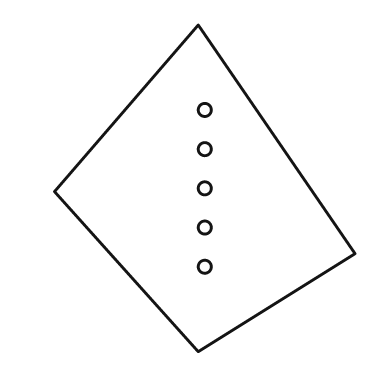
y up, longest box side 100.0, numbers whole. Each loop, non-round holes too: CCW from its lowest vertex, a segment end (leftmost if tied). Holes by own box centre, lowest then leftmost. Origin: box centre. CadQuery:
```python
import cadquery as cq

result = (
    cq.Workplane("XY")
    .moveTo(-2.0, -50.0)
    .lineTo(46.0, -20.0)
    .lineTo(-2.0, 50.0)
    .lineTo(-46.0, -1.0)
    .close()
    .moveTo(0.0, -24.0)
    .circle(2.0)
    .moveTo(0.0, -12.0)
    .circle(2.0)
    .moveTo(0.0, 0.0)
    .circle(2.0)
    .moveTo(0.0, 12.0)
    .circle(2.0)
    .moveTo(0.0, 24.0)
    .circle(2.0)
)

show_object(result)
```